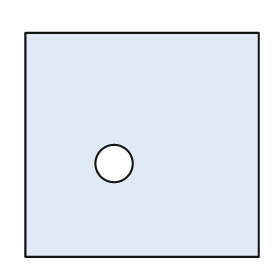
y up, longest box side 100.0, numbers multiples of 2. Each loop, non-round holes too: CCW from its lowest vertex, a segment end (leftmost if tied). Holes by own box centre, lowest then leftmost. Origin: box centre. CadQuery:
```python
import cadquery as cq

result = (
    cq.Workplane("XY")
    .moveTo(-50.0, -48.0)
    .lineTo(50.0, -48.0)
    .lineTo(50.0, 48.0)
    .lineTo(-50.0, 48.0)
    .close()
    .moveTo(-12.0, -8.0)
    .circle(8.0)
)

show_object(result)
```